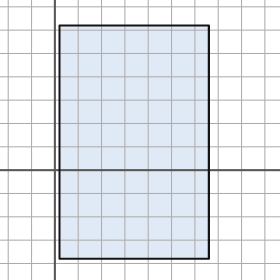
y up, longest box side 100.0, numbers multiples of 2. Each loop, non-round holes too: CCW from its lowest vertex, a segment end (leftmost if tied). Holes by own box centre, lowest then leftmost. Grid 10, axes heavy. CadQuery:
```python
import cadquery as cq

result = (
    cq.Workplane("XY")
    .moveTo(2.0, -38.0)
    .lineTo(66.0, -38.0)
    .lineTo(66.0, 62.0)
    .lineTo(2.0, 62.0)
    .close()
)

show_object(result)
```